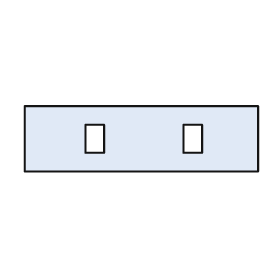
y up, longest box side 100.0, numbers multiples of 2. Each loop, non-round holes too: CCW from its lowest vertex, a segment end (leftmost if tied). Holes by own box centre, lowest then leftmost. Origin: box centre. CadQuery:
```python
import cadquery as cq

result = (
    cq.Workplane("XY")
    .moveTo(-50.0, -14.0)
    .lineTo(50.0, -14.0)
    .lineTo(50.0, 14.0)
    .lineTo(-50.0, 14.0)
    .close()
    .moveTo(-24.0, -6.0)
    .lineTo(-16.0, -6.0)
    .lineTo(-16.0, 6.0)
    .lineTo(-24.0, 6.0)
    .close()
    .moveTo(18.0, -6.0)
    .lineTo(26.0, -6.0)
    .lineTo(26.0, 6.0)
    .lineTo(18.0, 6.0)
    .close()
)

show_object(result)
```